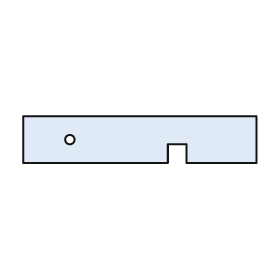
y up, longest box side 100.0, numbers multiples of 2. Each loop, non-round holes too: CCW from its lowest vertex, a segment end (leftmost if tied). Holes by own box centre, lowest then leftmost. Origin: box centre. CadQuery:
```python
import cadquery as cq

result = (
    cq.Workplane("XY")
    .moveTo(-50.0, -10.0)
    .lineTo(12.0, -10.0)
    .lineTo(12.0, -2.0)
    .lineTo(20.0, -2.0)
    .lineTo(20.0, -10.0)
    .lineTo(50.0, -10.0)
    .lineTo(50.0, 10.0)
    .lineTo(-50.0, 10.0)
    .close()
    .moveTo(-30.0, 0.0)
    .circle(2.0)
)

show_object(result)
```